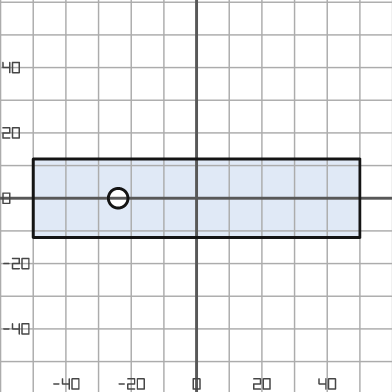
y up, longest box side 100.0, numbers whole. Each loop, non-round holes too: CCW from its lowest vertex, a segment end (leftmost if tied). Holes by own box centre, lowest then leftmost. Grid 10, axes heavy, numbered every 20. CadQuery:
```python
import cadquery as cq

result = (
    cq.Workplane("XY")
    .moveTo(-50.0, -12.0)
    .lineTo(50.0, -12.0)
    .lineTo(50.0, 12.0)
    .lineTo(-50.0, 12.0)
    .close()
    .moveTo(-24.0, 0.0)
    .circle(3.0)
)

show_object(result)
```